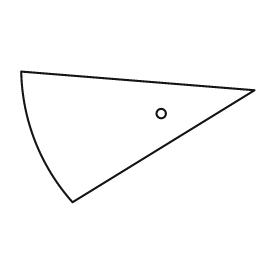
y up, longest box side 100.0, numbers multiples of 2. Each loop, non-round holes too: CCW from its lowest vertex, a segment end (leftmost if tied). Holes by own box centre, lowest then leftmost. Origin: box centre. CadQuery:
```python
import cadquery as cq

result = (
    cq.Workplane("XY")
    .moveTo(-28.0, -28.0)
    .lineTo(50.0, 20.0)
    .lineTo(-50.0, 28.0)
    .threePointArc((-44.0, -2.0), (-28.0, -28.0))
    .close()
    .moveTo(10.0, 10.0)
    .circle(2.0)
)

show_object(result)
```